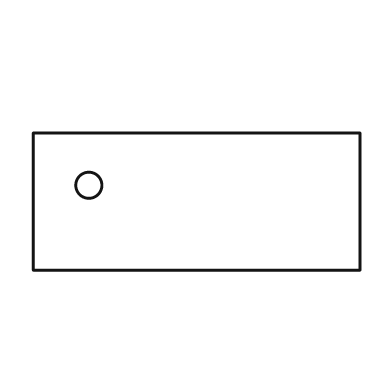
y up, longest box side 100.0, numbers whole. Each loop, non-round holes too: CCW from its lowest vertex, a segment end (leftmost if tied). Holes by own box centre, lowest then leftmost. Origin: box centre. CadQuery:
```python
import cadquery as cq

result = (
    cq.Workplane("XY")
    .moveTo(-50.0, -21.0)
    .lineTo(50.0, -21.0)
    .lineTo(50.0, 21.0)
    .lineTo(-50.0, 21.0)
    .close()
    .moveTo(-33.0, 5.0)
    .circle(4.0)
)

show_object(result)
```